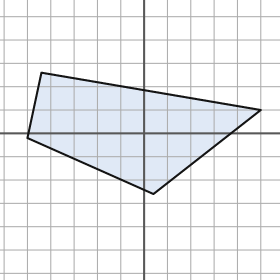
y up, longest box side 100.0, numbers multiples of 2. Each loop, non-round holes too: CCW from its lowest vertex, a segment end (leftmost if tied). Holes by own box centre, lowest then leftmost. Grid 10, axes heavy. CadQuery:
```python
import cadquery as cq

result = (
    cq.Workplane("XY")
    .moveTo(4.0, -26.0)
    .lineTo(50.0, 10.0)
    .lineTo(-44.0, 26.0)
    .lineTo(-50.0, -2.0)
    .close()
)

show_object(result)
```